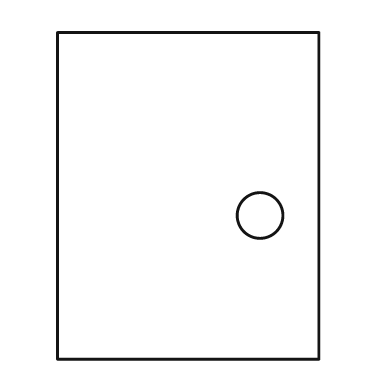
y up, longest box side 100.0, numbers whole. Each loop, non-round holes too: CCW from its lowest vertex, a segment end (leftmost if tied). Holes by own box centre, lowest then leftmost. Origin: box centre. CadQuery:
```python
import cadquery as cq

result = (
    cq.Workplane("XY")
    .moveTo(-40.0, -50.0)
    .lineTo(40.0, -50.0)
    .lineTo(40.0, 50.0)
    .lineTo(-40.0, 50.0)
    .close()
    .moveTo(22.0, -6.0)
    .circle(7.0)
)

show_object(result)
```